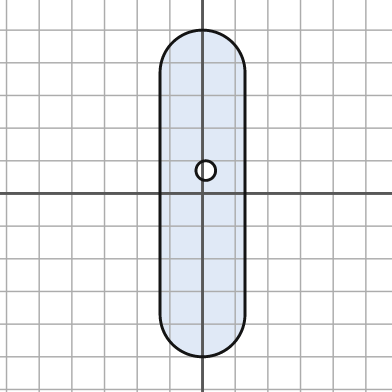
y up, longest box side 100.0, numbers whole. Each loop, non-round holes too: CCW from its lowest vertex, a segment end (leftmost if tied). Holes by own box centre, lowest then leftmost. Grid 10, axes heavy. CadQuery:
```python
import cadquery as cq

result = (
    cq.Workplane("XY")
    .moveTo(-13.0, -37.0)
    .threePointArc((0.0, -50.0), (13.0, -37.0))
    .lineTo(13.0, 37.0)
    .threePointArc((0.0, 50.0), (-13.0, 37.0))
    .close()
    .moveTo(1.0, 7.0)
    .circle(3.0)
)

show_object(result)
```